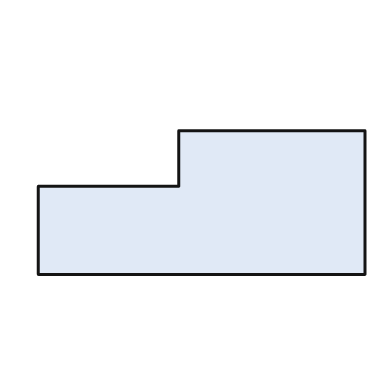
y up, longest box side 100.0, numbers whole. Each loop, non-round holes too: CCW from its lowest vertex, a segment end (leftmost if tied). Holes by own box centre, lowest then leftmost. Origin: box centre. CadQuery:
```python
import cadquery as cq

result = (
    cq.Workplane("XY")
    .moveTo(-50.0, -22.0)
    .lineTo(50.0, -22.0)
    .lineTo(50.0, 22.0)
    .lineTo(-7.0, 22.0)
    .lineTo(-7.0, 5.0)
    .lineTo(-50.0, 5.0)
    .close()
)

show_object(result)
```